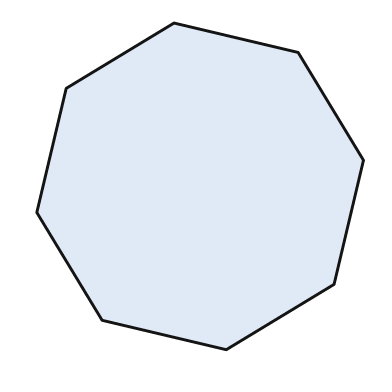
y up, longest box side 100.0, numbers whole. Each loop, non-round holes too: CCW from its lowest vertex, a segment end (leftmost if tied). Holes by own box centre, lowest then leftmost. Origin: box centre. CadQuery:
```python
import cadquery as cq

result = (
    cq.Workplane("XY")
    .moveTo(8.0, -50.0)
    .lineTo(41.0, -30.0)
    .lineTo(50.0, 8.0)
    .lineTo(30.0, 41.0)
    .lineTo(-8.0, 50.0)
    .lineTo(-41.0, 30.0)
    .lineTo(-50.0, -8.0)
    .lineTo(-30.0, -41.0)
    .close()
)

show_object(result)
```